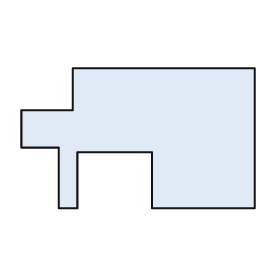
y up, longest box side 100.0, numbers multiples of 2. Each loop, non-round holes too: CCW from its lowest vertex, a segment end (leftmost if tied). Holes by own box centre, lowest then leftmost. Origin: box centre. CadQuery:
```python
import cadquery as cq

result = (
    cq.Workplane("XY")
    .moveTo(-34.0, -30.0)
    .lineTo(-26.0, -30.0)
    .lineTo(-26.0, -6.0)
    .lineTo(6.0, -6.0)
    .lineTo(6.0, -30.0)
    .lineTo(50.0, -30.0)
    .lineTo(50.0, 30.0)
    .lineTo(-28.0, 30.0)
    .lineTo(-28.0, 12.0)
    .lineTo(-50.0, 12.0)
    .lineTo(-50.0, -4.0)
    .lineTo(-34.0, -4.0)
    .close()
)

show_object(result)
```